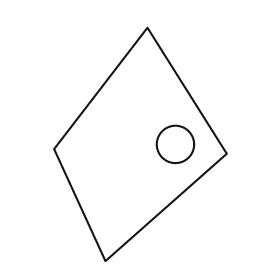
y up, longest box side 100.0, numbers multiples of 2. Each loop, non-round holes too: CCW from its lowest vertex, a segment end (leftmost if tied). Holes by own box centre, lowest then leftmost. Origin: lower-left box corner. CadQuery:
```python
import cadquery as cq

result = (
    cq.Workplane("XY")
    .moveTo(22.0, 0.0)
    .lineTo(74.0, 46.0)
    .lineTo(40.0, 100.0)
    .lineTo(0.0, 48.0)
    .close()
    .moveTo(52.0, 50.0)
    .circle(8.0)
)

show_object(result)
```